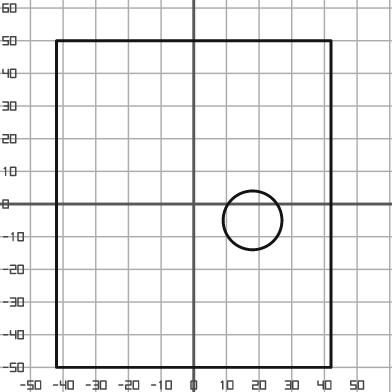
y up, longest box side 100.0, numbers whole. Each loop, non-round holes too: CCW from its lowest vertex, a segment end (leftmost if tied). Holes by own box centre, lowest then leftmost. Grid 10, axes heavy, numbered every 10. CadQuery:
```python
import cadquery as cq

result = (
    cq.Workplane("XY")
    .moveTo(-42.0, -50.0)
    .lineTo(42.0, -50.0)
    .lineTo(42.0, 50.0)
    .lineTo(-42.0, 50.0)
    .close()
    .moveTo(18.0, -5.0)
    .circle(9.0)
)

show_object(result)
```